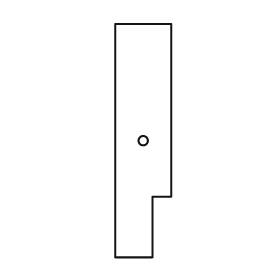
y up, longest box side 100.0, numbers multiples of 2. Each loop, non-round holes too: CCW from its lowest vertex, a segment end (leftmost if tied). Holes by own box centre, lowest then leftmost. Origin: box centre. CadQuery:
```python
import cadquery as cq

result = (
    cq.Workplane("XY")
    .moveTo(-12.0, -50.0)
    .lineTo(4.0, -50.0)
    .lineTo(4.0, -24.0)
    .lineTo(12.0, -24.0)
    .lineTo(12.0, 50.0)
    .lineTo(-12.0, 50.0)
    .close()
    .moveTo(0.0, 0.0)
    .circle(2.0)
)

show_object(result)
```